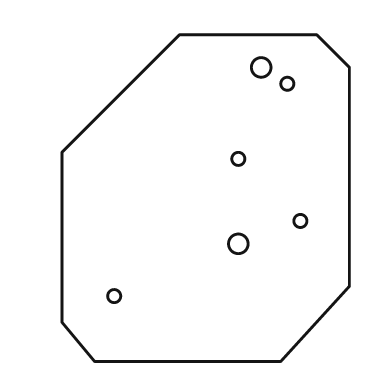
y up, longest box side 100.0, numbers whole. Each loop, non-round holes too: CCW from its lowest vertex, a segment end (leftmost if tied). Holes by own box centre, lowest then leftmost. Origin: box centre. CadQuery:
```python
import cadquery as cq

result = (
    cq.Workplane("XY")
    .moveTo(-34.0, -50.0)
    .lineTo(23.0, -50.0)
    .lineTo(44.0, -27.0)
    .lineTo(44.0, 40.0)
    .lineTo(34.0, 50.0)
    .lineTo(-8.0, 50.0)
    .lineTo(-44.0, 14.0)
    .lineTo(-44.0, -38.0)
    .close()
    .moveTo(-28.0, -30.0)
    .circle(2.0)
    .moveTo(10.0, -14.0)
    .circle(3.0)
    .moveTo(29.0, -7.0)
    .circle(2.0)
    .moveTo(10.0, 12.0)
    .circle(2.0)
    .moveTo(25.0, 35.0)
    .circle(2.0)
    .moveTo(17.0, 40.0)
    .circle(3.0)
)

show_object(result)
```